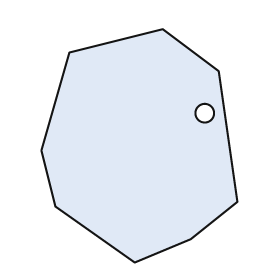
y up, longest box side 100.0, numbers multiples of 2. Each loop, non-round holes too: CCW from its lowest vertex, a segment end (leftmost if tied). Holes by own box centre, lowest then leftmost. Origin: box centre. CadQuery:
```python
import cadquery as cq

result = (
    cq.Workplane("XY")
    .moveTo(-2.0, -50.0)
    .lineTo(22.0, -40.0)
    .lineTo(42.0, -24.0)
    .lineTo(34.0, 32.0)
    .lineTo(10.0, 50.0)
    .lineTo(-30.0, 40.0)
    .lineTo(-42.0, -2.0)
    .lineTo(-36.0, -26.0)
    .close()
    .moveTo(28.0, 14.0)
    .circle(4.0)
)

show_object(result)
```